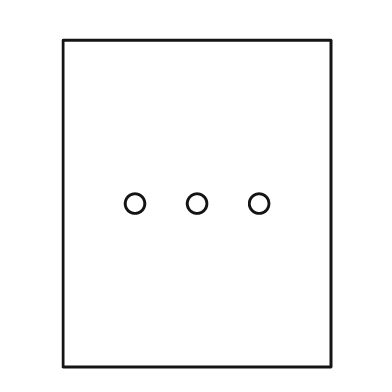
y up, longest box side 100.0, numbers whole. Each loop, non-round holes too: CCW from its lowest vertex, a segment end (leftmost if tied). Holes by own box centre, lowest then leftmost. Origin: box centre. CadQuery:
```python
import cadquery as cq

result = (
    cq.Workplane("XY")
    .moveTo(-41.0, -50.0)
    .lineTo(41.0, -50.0)
    .lineTo(41.0, 50.0)
    .lineTo(-41.0, 50.0)
    .close()
    .moveTo(-19.0, 0.0)
    .circle(3.0)
    .moveTo(0.0, 0.0)
    .circle(3.0)
    .moveTo(19.0, 0.0)
    .circle(3.0)
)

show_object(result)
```